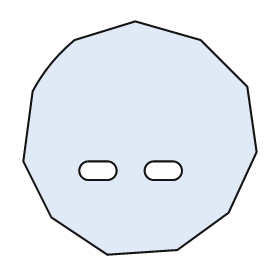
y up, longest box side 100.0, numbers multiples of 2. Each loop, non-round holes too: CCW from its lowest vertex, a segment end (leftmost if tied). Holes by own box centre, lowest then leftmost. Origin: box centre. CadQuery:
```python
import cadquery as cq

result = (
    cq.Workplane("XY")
    .moveTo(-14.0, -50.0)
    .lineTo(16.0, -48.0)
    .lineTo(38.0, -32.0)
    .lineTo(50.0, -6.0)
    .lineTo(46.0, 22.0)
    .lineTo(26.0, 42.0)
    .lineTo(-2.0, 50.0)
    .lineTo(-28.0, 42.0)
    .threePointArc((-38.0, 32.0), (-46.0, 20.0))
    .lineTo(-50.0, -10.0)
    .lineTo(-38.0, -34.0)
    .close()
    .moveTo(-22.0, -18.0)
    .lineTo(-14.0, -18.0)
    .threePointArc((-10.0, -14.0), (-14.0, -10.0))
    .lineTo(-22.0, -10.0)
    .threePointArc((-26.0, -14.0), (-22.0, -18.0))
    .close()
    .moveTo(6.0, -18.0)
    .lineTo(14.0, -18.0)
    .threePointArc((18.0, -14.0), (14.0, -10.0))
    .lineTo(6.0, -10.0)
    .threePointArc((2.0, -14.0), (6.0, -18.0))
    .close()
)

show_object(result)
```